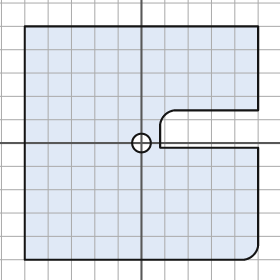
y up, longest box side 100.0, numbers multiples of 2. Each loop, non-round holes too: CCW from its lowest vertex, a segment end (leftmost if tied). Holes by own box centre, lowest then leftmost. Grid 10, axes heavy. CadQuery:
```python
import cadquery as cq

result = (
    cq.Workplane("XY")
    .moveTo(-50.0, -50.0)
    .lineTo(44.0, -50.0)
    .threePointArc((48.0, -48.0), (50.0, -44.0))
    .lineTo(50.0, -2.0)
    .lineTo(8.0, -2.0)
    .lineTo(8.0, 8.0)
    .threePointArc((10.0, 12.0), (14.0, 14.0))
    .lineTo(50.0, 14.0)
    .lineTo(50.0, 50.0)
    .lineTo(-50.0, 50.0)
    .close()
    .moveTo(0.0, 0.0)
    .circle(4.0)
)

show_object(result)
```